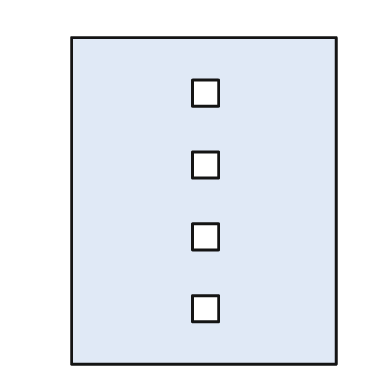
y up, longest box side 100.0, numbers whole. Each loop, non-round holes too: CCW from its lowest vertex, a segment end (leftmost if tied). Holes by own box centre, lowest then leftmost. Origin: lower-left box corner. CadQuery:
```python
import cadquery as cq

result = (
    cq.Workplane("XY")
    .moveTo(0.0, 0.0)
    .lineTo(81.0, 0.0)
    .lineTo(81.0, 100.0)
    .lineTo(0.0, 100.0)
    .close()
    .moveTo(37.0, 13.0)
    .lineTo(45.0, 13.0)
    .lineTo(45.0, 21.0)
    .lineTo(37.0, 21.0)
    .close()
    .moveTo(37.0, 35.0)
    .lineTo(45.0, 35.0)
    .lineTo(45.0, 43.0)
    .lineTo(37.0, 43.0)
    .close()
    .moveTo(37.0, 57.0)
    .lineTo(45.0, 57.0)
    .lineTo(45.0, 65.0)
    .lineTo(37.0, 65.0)
    .close()
    .moveTo(37.0, 79.0)
    .lineTo(45.0, 79.0)
    .lineTo(45.0, 87.0)
    .lineTo(37.0, 87.0)
    .close()
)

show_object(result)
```